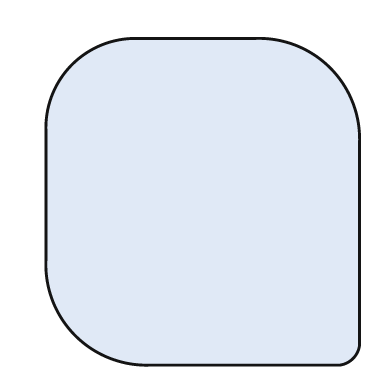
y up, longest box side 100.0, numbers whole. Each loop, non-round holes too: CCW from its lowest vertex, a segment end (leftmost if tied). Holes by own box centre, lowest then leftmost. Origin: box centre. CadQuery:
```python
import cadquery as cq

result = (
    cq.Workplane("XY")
    .moveTo(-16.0, -50.0)
    .lineTo(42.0, -50.0)
    .threePointArc((46.0, -48.0), (48.0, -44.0))
    .lineTo(48.0, 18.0)
    .threePointArc((39.0, 41.0), (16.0, 50.0))
    .lineTo(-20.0, 50.0)
    .threePointArc((-40.0, 42.0), (-48.0, 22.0))
    .lineTo(-48.0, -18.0)
    .threePointArc((-39.0, -41.0), (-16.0, -50.0))
    .close()
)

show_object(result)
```